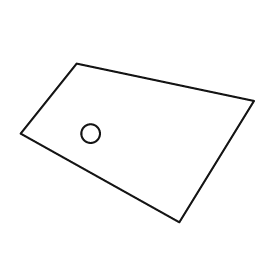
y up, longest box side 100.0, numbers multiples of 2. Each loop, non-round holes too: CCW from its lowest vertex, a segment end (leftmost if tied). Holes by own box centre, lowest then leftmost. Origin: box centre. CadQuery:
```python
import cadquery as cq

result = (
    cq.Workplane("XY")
    .moveTo(18.0, -34.0)
    .lineTo(50.0, 18.0)
    .lineTo(-26.0, 34.0)
    .lineTo(-50.0, 4.0)
    .close()
    .moveTo(-20.0, 4.0)
    .circle(4.0)
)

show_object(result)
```